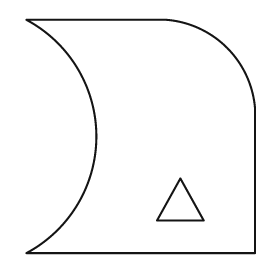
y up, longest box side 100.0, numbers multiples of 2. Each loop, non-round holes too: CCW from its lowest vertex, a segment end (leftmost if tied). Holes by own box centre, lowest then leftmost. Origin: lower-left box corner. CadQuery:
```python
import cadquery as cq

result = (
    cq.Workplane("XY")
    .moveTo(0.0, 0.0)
    .lineTo(98.0, 0.0)
    .lineTo(98.0, 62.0)
    .threePointArc((86.0, 88.0), (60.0, 100.0))
    .lineTo(0.0, 100.0)
    .threePointArc((30.0, 50.0), (0.0, 0.0))
    .close()
    .moveTo(56.0, 14.0)
    .lineTo(76.0, 14.0)
    .lineTo(66.0, 32.0)
    .close()
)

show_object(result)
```